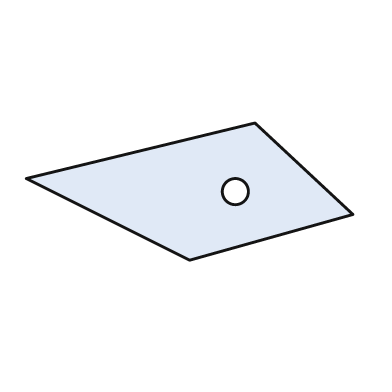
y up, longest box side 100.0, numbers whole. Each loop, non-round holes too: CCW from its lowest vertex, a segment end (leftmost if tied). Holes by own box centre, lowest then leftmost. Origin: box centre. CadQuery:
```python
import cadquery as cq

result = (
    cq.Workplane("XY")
    .moveTo(0.0, -21.0)
    .lineTo(50.0, -7.0)
    .lineTo(20.0, 21.0)
    .lineTo(-50.0, 4.0)
    .close()
    .moveTo(14.0, 0.0)
    .circle(4.0)
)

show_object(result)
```